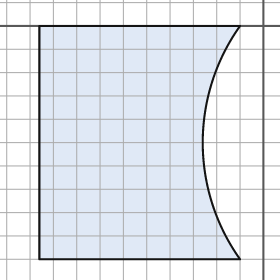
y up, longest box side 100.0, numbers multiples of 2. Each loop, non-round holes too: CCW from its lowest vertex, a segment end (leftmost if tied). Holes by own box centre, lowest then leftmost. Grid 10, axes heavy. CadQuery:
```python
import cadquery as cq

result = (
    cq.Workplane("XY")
    .moveTo(-96.0, -100.0)
    .lineTo(-10.0, -100.0)
    .threePointArc((-26.0, -50.0), (-10.0, 0.0))
    .lineTo(-96.0, 0.0)
    .close()
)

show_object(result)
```